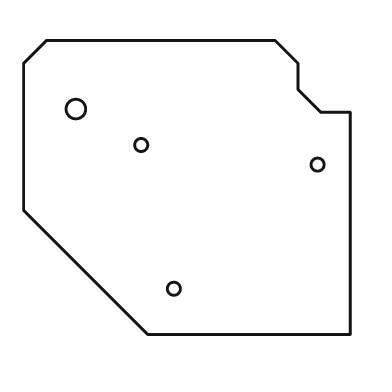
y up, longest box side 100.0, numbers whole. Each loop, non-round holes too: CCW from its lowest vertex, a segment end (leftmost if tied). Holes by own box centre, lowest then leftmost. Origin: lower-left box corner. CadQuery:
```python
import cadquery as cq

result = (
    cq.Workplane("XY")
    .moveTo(38.0, 0.0)
    .lineTo(100.0, 0.0)
    .lineTo(100.0, 68.0)
    .lineTo(91.0, 68.0)
    .lineTo(84.0, 75.0)
    .lineTo(84.0, 83.0)
    .lineTo(77.0, 90.0)
    .lineTo(7.0, 90.0)
    .lineTo(0.0, 83.0)
    .lineTo(0.0, 38.0)
    .close()
    .moveTo(46.0, 14.0)
    .circle(2.0)
    .moveTo(90.0, 52.0)
    .circle(2.0)
    .moveTo(36.0, 58.0)
    .circle(2.0)
    .moveTo(16.0, 69.0)
    .circle(3.0)
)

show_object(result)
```